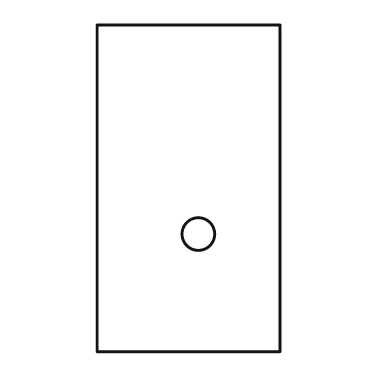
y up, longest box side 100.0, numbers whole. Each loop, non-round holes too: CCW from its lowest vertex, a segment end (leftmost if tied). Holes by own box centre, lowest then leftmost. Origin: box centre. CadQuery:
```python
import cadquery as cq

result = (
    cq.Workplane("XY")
    .moveTo(-28.0, -50.0)
    .lineTo(28.0, -50.0)
    .lineTo(28.0, 50.0)
    .lineTo(-28.0, 50.0)
    .close()
    .moveTo(3.0, -14.0)
    .circle(5.0)
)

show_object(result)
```